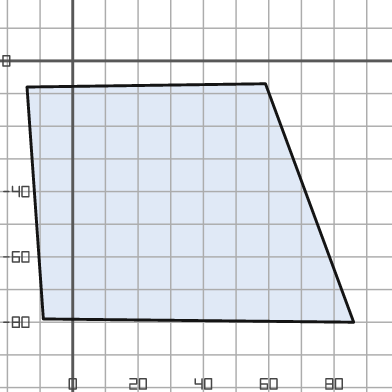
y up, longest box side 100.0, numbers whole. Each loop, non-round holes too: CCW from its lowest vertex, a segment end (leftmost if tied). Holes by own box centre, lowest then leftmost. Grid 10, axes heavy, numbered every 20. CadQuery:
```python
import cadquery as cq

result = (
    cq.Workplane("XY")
    .moveTo(86.0, -80.0)
    .lineTo(59.0, -7.0)
    .lineTo(-14.0, -8.0)
    .lineTo(-9.0, -79.0)
    .close()
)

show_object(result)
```